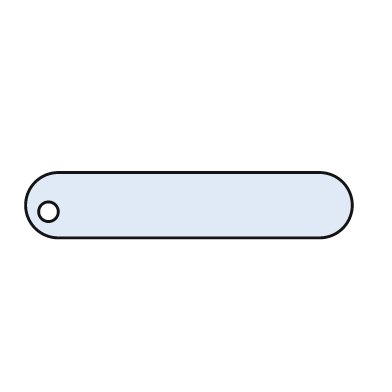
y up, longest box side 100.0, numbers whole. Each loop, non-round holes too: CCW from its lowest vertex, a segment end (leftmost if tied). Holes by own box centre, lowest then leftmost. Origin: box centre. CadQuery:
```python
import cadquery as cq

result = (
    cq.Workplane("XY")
    .moveTo(-40.0, -10.0)
    .lineTo(40.0, -10.0)
    .threePointArc((50.0, 0.0), (40.0, 10.0))
    .lineTo(-40.0, 10.0)
    .threePointArc((-50.0, 0.0), (-40.0, -10.0))
    .close()
    .moveTo(-43.0, -2.0)
    .circle(3.0)
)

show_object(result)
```